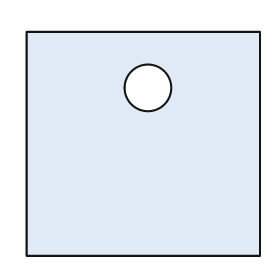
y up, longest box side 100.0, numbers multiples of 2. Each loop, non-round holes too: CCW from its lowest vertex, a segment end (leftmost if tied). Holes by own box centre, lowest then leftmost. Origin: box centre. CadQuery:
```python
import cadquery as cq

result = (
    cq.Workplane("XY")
    .moveTo(-50.0, -48.0)
    .lineTo(50.0, -48.0)
    .lineTo(50.0, 48.0)
    .lineTo(-50.0, 48.0)
    .close()
    .moveTo(2.0, 24.0)
    .circle(10.0)
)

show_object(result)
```